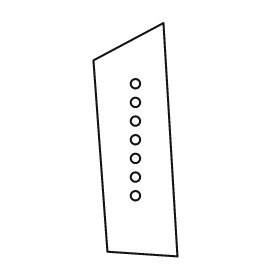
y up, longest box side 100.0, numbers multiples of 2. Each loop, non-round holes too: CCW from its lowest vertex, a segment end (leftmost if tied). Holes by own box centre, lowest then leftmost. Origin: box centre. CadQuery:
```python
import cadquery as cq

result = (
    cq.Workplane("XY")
    .moveTo(18.0, -50.0)
    .lineTo(12.0, 50.0)
    .lineTo(-18.0, 34.0)
    .lineTo(-12.0, -48.0)
    .close()
    .moveTo(0.0, -24.0)
    .circle(2.0)
    .moveTo(0.0, -16.0)
    .circle(2.0)
    .moveTo(0.0, -8.0)
    .circle(2.0)
    .moveTo(0.0, 0.0)
    .circle(2.0)
    .moveTo(0.0, 8.0)
    .circle(2.0)
    .moveTo(0.0, 16.0)
    .circle(2.0)
    .moveTo(0.0, 24.0)
    .circle(2.0)
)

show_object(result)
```